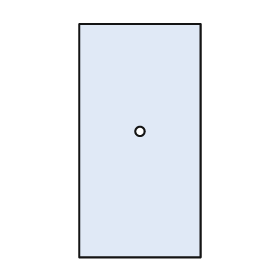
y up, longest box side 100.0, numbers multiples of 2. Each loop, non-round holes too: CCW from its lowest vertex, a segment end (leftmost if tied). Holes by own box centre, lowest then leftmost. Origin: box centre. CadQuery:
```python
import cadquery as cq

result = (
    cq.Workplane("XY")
    .moveTo(-26.0, -50.0)
    .lineTo(26.0, -50.0)
    .lineTo(26.0, 50.0)
    .lineTo(-26.0, 50.0)
    .close()
    .moveTo(0.0, 4.0)
    .circle(2.0)
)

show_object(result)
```